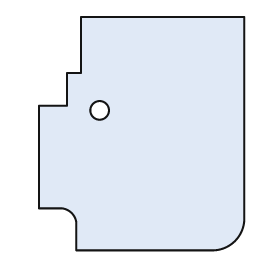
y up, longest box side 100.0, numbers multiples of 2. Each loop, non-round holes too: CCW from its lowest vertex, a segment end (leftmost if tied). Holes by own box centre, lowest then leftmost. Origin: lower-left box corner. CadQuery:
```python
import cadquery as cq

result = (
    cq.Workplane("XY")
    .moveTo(16.0, 0.0)
    .lineTo(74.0, 0.0)
    .threePointArc((84.0, 4.0), (88.0, 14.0))
    .lineTo(88.0, 100.0)
    .lineTo(18.0, 100.0)
    .lineTo(18.0, 76.0)
    .lineTo(12.0, 76.0)
    .lineTo(12.0, 62.0)
    .lineTo(0.0, 62.0)
    .lineTo(0.0, 18.0)
    .lineTo(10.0, 18.0)
    .threePointArc((14.0, 16.0), (16.0, 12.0))
    .close()
    .moveTo(26.0, 60.0)
    .circle(4.0)
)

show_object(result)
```